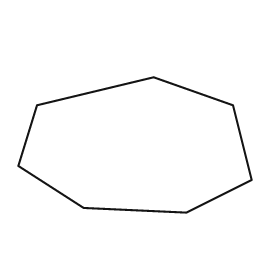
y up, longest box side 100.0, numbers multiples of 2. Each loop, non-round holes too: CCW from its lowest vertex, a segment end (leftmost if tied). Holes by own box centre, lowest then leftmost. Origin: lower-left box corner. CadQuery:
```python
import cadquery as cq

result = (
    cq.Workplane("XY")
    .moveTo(72.0, 0.0)
    .lineTo(100.0, 14.0)
    .lineTo(92.0, 46.0)
    .lineTo(58.0, 58.0)
    .lineTo(8.0, 46.0)
    .lineTo(0.0, 20.0)
    .lineTo(28.0, 2.0)
    .close()
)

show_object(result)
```